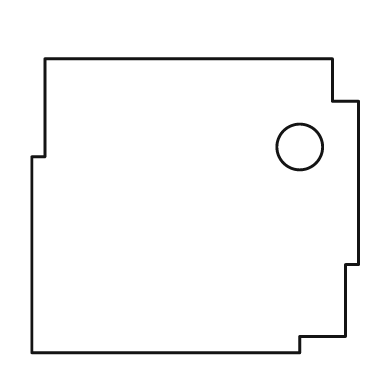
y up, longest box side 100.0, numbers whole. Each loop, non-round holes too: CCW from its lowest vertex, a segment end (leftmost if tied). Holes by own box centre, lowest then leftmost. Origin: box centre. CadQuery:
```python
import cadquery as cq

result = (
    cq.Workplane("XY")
    .moveTo(-50.0, -45.0)
    .lineTo(32.0, -45.0)
    .lineTo(32.0, -40.0)
    .lineTo(46.0, -40.0)
    .lineTo(46.0, -18.0)
    .lineTo(50.0, -18.0)
    .lineTo(50.0, 32.0)
    .lineTo(42.0, 32.0)
    .lineTo(42.0, 45.0)
    .lineTo(-46.0, 45.0)
    .lineTo(-46.0, 15.0)
    .lineTo(-50.0, 15.0)
    .close()
    .moveTo(32.0, 18.0)
    .circle(7.0)
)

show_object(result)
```